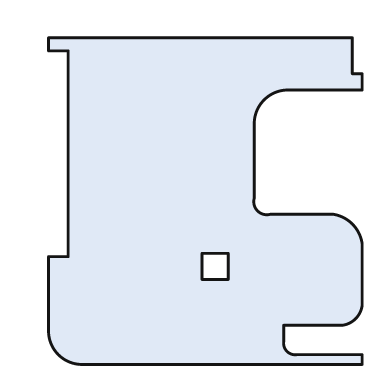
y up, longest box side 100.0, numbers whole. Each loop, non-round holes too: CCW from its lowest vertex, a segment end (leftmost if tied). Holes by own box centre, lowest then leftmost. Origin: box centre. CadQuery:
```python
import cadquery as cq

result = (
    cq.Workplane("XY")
    .moveTo(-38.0, -50.0)
    .lineTo(48.0, -50.0)
    .lineTo(48.0, -47.0)
    .lineTo(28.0, -47.0)
    .threePointArc((25.0, -46.0), (24.0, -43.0))
    .lineTo(24.0, -38.0)
    .lineTo(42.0, -38.0)
    .threePointArc((46.0, -36.0), (48.0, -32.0))
    .lineTo(48.0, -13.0)
    .threePointArc((45.0, -7.0), (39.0, -4.0))
    .lineTo(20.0, -4.0)
    .threePointArc((16.0, -3.0), (15.0, 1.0))
    .lineTo(15.0, 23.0)
    .threePointArc((18.0, 31.0), (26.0, 34.0))
    .lineTo(48.0, 34.0)
    .lineTo(48.0, 39.0)
    .lineTo(45.0, 39.0)
    .lineTo(45.0, 50.0)
    .lineTo(-48.0, 50.0)
    .lineTo(-48.0, 46.0)
    .lineTo(-42.0, 46.0)
    .lineTo(-42.0, -17.0)
    .lineTo(-48.0, -17.0)
    .lineTo(-48.0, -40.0)
    .threePointArc((-45.0, -47.0), (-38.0, -50.0))
    .close()
    .moveTo(-1.0, -24.0)
    .lineTo(7.0, -24.0)
    .lineTo(7.0, -16.0)
    .lineTo(-1.0, -16.0)
    .close()
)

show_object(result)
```